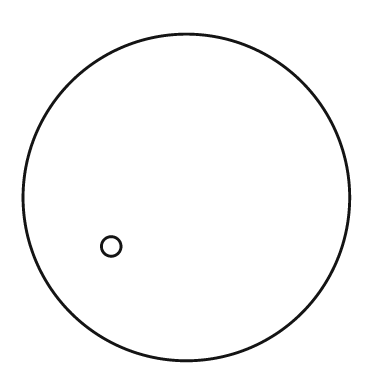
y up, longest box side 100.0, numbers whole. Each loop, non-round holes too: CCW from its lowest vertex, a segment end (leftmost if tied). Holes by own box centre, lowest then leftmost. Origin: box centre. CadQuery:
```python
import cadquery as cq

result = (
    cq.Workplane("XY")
    .moveTo(0.0, 0.0)
    .circle(50.0)
    .moveTo(-23.0, -15.0)
    .circle(3.0)
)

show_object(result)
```